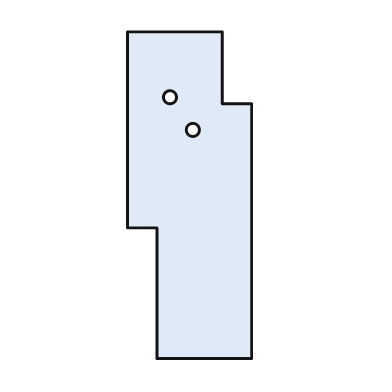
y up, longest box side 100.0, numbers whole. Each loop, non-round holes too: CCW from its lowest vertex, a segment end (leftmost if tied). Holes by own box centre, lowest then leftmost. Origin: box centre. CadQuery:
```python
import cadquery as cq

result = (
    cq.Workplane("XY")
    .moveTo(-10.0, -50.0)
    .lineTo(19.0, -50.0)
    .lineTo(19.0, 28.0)
    .lineTo(10.0, 28.0)
    .lineTo(10.0, 50.0)
    .lineTo(-19.0, 50.0)
    .lineTo(-19.0, -10.0)
    .lineTo(-10.0, -10.0)
    .close()
    .moveTo(1.0, 20.0)
    .circle(2.0)
    .moveTo(-6.0, 30.0)
    .circle(2.0)
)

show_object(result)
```